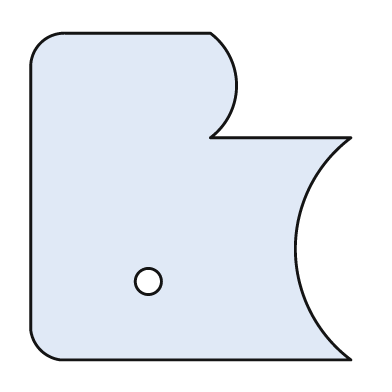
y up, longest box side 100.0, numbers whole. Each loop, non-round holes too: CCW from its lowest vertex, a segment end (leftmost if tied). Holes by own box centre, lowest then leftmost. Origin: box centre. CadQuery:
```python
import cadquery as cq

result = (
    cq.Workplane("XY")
    .moveTo(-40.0, -50.0)
    .lineTo(49.0, -50.0)
    .threePointArc((32.0, -16.0), (49.0, 18.0))
    .lineTo(6.0, 18.0)
    .threePointArc((14.0, 34.0), (6.0, 50.0))
    .lineTo(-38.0, 50.0)
    .threePointArc((-46.0, 47.0), (-49.0, 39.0))
    .lineTo(-49.0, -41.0)
    .threePointArc((-46.0, -47.0), (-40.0, -50.0))
    .close()
    .moveTo(-13.0, -26.0)
    .circle(4.0)
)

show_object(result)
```